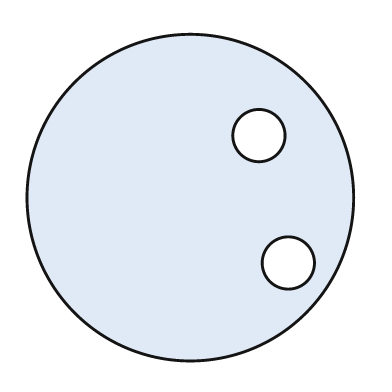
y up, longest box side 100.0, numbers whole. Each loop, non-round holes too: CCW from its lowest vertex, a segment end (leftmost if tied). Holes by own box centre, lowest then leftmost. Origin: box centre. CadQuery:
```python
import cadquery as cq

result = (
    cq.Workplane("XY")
    .moveTo(0.0, 0.0)
    .circle(50.0)
    .moveTo(30.0, -20.0)
    .circle(8.0)
    .moveTo(21.0, 19.0)
    .circle(8.0)
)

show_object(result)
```